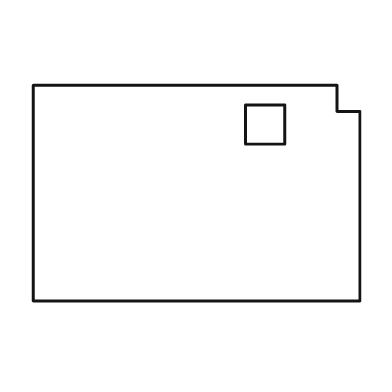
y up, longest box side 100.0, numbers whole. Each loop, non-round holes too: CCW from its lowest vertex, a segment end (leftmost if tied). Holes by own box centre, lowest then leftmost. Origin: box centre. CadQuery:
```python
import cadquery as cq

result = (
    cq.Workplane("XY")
    .moveTo(-50.0, -33.0)
    .lineTo(50.0, -33.0)
    .lineTo(50.0, 25.0)
    .lineTo(43.0, 25.0)
    .lineTo(43.0, 33.0)
    .lineTo(-50.0, 33.0)
    .close()
    .moveTo(15.0, 15.0)
    .lineTo(27.0, 15.0)
    .lineTo(27.0, 27.0)
    .lineTo(15.0, 27.0)
    .close()
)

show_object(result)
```